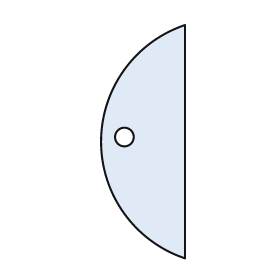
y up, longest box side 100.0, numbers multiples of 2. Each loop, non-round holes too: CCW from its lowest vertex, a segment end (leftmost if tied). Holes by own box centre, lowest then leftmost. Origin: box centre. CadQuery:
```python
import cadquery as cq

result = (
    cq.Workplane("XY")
    .moveTo(18.0, -50.0)
    .lineTo(18.0, 50.0)
    .threePointArc((-18.0, 0.0), (18.0, -50.0))
    .close()
    .moveTo(-8.0, 2.0)
    .circle(4.0)
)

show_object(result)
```